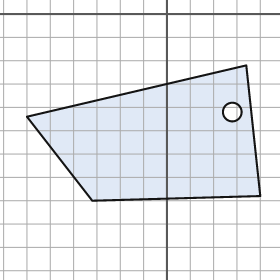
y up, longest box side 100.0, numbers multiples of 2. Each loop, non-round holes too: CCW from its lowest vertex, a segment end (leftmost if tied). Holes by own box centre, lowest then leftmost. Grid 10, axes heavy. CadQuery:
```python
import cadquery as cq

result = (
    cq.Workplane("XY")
    .moveTo(-32.0, -80.0)
    .lineTo(40.0, -78.0)
    .lineTo(34.0, -22.0)
    .lineTo(-60.0, -44.0)
    .close()
    .moveTo(28.0, -42.0)
    .circle(4.0)
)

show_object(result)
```